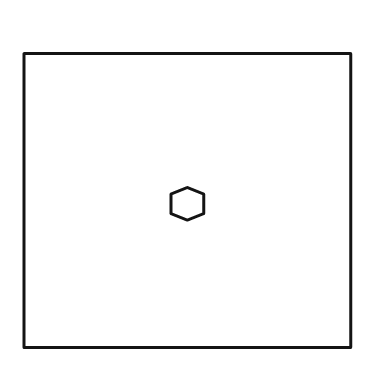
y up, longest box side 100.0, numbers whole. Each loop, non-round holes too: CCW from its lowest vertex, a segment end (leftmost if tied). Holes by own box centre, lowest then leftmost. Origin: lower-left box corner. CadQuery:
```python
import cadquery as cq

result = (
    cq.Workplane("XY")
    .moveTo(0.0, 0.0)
    .lineTo(100.0, 0.0)
    .lineTo(100.0, 90.0)
    .lineTo(0.0, 90.0)
    .close()
    .moveTo(50.0, 39.0)
    .lineTo(55.0, 41.0)
    .lineTo(55.0, 47.0)
    .lineTo(50.0, 49.0)
    .lineTo(45.0, 47.0)
    .lineTo(45.0, 41.0)
    .close()
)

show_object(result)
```